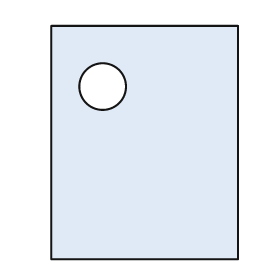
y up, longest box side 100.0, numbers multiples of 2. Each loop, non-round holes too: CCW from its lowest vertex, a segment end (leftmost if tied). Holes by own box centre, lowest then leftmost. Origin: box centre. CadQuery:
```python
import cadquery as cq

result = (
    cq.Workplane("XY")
    .moveTo(-40.0, -50.0)
    .lineTo(40.0, -50.0)
    .lineTo(40.0, 50.0)
    .lineTo(-40.0, 50.0)
    .close()
    .moveTo(-18.0, 24.0)
    .circle(10.0)
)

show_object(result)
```